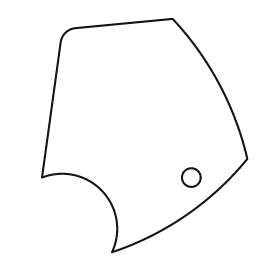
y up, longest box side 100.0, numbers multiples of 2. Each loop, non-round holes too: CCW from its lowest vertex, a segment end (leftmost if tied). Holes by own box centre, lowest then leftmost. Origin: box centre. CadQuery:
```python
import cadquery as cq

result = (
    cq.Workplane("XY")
    .moveTo(-14.0, -50.0)
    .threePointArc((18.0, -34.0), (44.0, -10.0))
    .threePointArc((32.0, 22.0), (12.0, 50.0))
    .lineTo(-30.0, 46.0)
    .threePointArc((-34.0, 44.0), (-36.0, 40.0))
    .lineTo(-44.0, -18.0)
    .threePointArc((-18.0, -24.0), (-14.0, -50.0))
    .close()
    .moveTo(20.0, -18.0)
    .circle(4.0)
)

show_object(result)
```